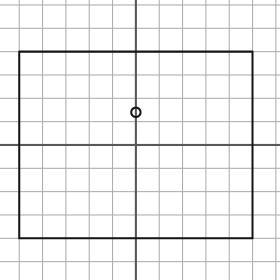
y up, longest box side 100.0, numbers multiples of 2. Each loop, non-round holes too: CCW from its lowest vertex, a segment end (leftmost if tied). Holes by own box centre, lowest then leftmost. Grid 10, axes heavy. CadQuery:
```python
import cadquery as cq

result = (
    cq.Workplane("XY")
    .moveTo(-50.0, -40.0)
    .lineTo(50.0, -40.0)
    .lineTo(50.0, 40.0)
    .lineTo(-50.0, 40.0)
    .close()
    .moveTo(0.0, 14.0)
    .circle(2.0)
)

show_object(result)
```